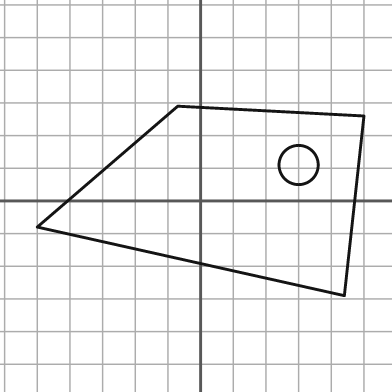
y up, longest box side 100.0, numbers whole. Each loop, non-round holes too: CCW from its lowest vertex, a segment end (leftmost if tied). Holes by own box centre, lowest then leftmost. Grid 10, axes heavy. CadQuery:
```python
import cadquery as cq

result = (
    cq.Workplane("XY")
    .moveTo(44.0, -29.0)
    .lineTo(50.0, 26.0)
    .lineTo(-7.0, 29.0)
    .lineTo(-50.0, -8.0)
    .close()
    .moveTo(30.0, 11.0)
    .circle(6.0)
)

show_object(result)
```